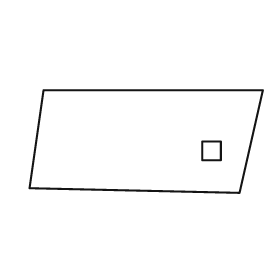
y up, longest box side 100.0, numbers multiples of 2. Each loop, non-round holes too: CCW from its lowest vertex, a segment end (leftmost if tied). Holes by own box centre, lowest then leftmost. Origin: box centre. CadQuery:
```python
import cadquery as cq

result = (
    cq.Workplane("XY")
    .moveTo(40.0, -22.0)
    .lineTo(50.0, 22.0)
    .lineTo(-44.0, 22.0)
    .lineTo(-50.0, -20.0)
    .close()
    .moveTo(24.0, -8.0)
    .lineTo(32.0, -8.0)
    .lineTo(32.0, 0.0)
    .lineTo(24.0, 0.0)
    .close()
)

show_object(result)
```